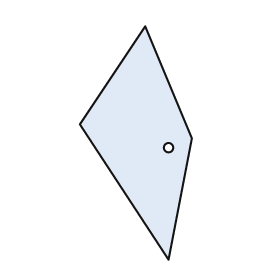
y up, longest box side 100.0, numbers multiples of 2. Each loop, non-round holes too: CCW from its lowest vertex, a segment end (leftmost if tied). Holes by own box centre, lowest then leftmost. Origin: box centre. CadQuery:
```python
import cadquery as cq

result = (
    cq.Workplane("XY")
    .moveTo(14.0, -50.0)
    .lineTo(24.0, 2.0)
    .lineTo(4.0, 50.0)
    .lineTo(-24.0, 8.0)
    .close()
    .moveTo(14.0, -2.0)
    .circle(2.0)
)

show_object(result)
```